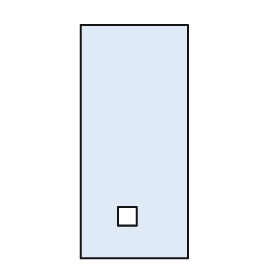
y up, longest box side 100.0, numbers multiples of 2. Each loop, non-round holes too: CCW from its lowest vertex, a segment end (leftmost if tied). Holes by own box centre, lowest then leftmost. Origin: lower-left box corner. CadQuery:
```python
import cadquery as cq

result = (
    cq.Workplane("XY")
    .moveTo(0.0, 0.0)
    .lineTo(46.0, 0.0)
    .lineTo(46.0, 100.0)
    .lineTo(0.0, 100.0)
    .close()
    .moveTo(16.0, 14.0)
    .lineTo(24.0, 14.0)
    .lineTo(24.0, 22.0)
    .lineTo(16.0, 22.0)
    .close()
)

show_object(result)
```